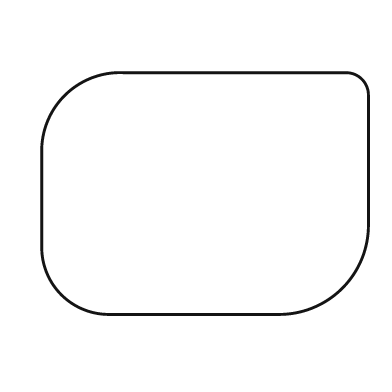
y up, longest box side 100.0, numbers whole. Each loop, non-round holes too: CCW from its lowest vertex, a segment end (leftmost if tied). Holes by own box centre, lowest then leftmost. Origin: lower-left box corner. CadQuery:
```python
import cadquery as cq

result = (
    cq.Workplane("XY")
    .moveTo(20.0, 0.0)
    .lineTo(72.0, 0.0)
    .threePointArc((92.0, 8.0), (100.0, 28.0))
    .lineTo(100.0, 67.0)
    .threePointArc((98.0, 72.0), (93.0, 74.0))
    .lineTo(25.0, 74.0)
    .threePointArc((7.0, 67.0), (0.0, 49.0))
    .lineTo(0.0, 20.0)
    .threePointArc((6.0, 6.0), (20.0, 0.0))
    .close()
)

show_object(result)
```